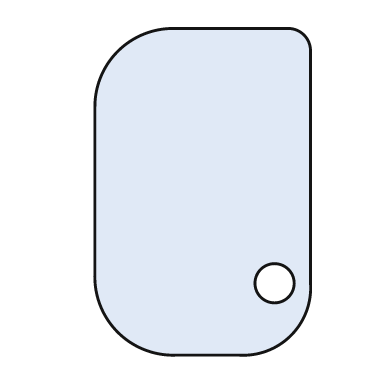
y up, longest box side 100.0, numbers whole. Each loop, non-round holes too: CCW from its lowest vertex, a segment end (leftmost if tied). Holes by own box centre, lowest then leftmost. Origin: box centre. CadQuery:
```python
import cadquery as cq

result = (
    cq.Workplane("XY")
    .moveTo(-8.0, -50.0)
    .lineTo(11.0, -50.0)
    .threePointArc((27.0, -44.0), (33.0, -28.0))
    .lineTo(33.0, 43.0)
    .threePointArc((31.0, 48.0), (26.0, 50.0))
    .lineTo(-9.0, 50.0)
    .threePointArc((-26.0, 43.0), (-33.0, 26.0))
    .lineTo(-33.0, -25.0)
    .threePointArc((-26.0, -43.0), (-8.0, -50.0))
    .close()
    .moveTo(22.0, -28.0)
    .circle(6.0)
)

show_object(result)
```